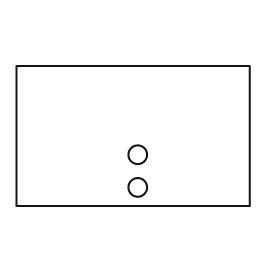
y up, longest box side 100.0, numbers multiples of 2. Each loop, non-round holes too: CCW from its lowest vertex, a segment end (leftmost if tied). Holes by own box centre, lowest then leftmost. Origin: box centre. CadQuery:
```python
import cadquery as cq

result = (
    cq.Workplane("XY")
    .moveTo(-50.0, -30.0)
    .lineTo(50.0, -30.0)
    .lineTo(50.0, 30.0)
    .lineTo(-50.0, 30.0)
    .close()
    .moveTo(2.0, -22.0)
    .circle(4.0)
    .moveTo(2.0, -8.0)
    .circle(4.0)
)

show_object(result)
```